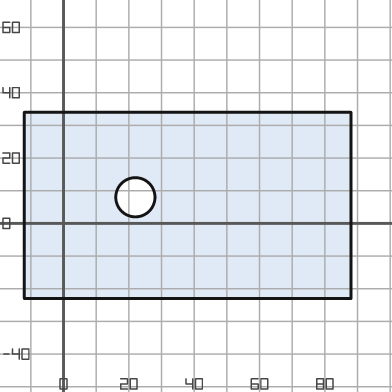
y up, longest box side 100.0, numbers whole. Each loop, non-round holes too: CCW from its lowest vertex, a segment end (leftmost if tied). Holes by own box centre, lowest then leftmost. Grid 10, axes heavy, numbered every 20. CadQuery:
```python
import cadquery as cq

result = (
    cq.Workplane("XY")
    .moveTo(-12.0, -23.0)
    .lineTo(88.0, -23.0)
    .lineTo(88.0, 34.0)
    .lineTo(-12.0, 34.0)
    .close()
    .moveTo(22.0, 8.0)
    .circle(6.0)
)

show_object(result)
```